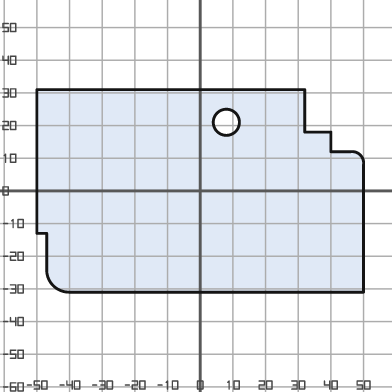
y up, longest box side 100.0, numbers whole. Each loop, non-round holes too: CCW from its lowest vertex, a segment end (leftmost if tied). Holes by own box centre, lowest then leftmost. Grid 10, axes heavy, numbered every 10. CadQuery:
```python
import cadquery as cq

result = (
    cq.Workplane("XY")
    .moveTo(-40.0, -31.0)
    .lineTo(50.0, -31.0)
    .lineTo(50.0, 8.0)
    .threePointArc((49.0, 11.0), (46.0, 12.0))
    .lineTo(40.0, 12.0)
    .lineTo(40.0, 18.0)
    .lineTo(32.0, 18.0)
    .lineTo(32.0, 31.0)
    .lineTo(-50.0, 31.0)
    .lineTo(-50.0, -13.0)
    .lineTo(-47.0, -13.0)
    .lineTo(-47.0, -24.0)
    .threePointArc((-45.0, -29.0), (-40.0, -31.0))
    .close()
    .moveTo(8.0, 21.0)
    .circle(4.0)
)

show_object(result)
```